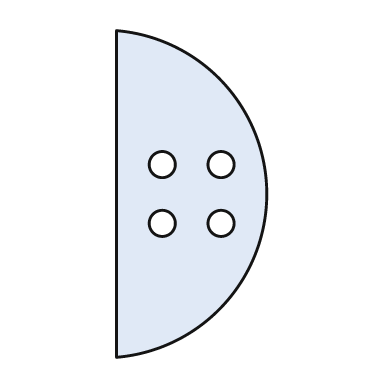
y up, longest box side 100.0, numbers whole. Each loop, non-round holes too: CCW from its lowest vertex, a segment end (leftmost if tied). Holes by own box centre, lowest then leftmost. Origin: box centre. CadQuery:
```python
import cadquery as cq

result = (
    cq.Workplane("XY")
    .moveTo(-23.0, -50.0)
    .threePointArc((23.0, 0.0), (-23.0, 50.0))
    .close()
    .moveTo(-9.0, -9.0)
    .circle(4.0)
    .moveTo(9.0, -9.0)
    .circle(4.0)
    .moveTo(-9.0, 9.0)
    .circle(4.0)
    .moveTo(9.0, 9.0)
    .circle(4.0)
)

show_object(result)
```